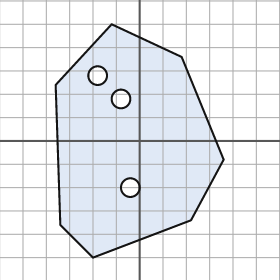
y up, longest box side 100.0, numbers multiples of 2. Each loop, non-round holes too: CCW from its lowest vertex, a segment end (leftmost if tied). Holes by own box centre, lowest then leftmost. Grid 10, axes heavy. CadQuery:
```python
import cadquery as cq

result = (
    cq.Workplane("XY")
    .moveTo(-20.0, -50.0)
    .lineTo(22.0, -34.0)
    .lineTo(36.0, -8.0)
    .lineTo(18.0, 36.0)
    .lineTo(-12.0, 50.0)
    .lineTo(-36.0, 24.0)
    .lineTo(-34.0, -36.0)
    .close()
    .moveTo(-4.0, -20.0)
    .circle(4.0)
    .moveTo(-8.0, 18.0)
    .circle(4.0)
    .moveTo(-18.0, 28.0)
    .circle(4.0)
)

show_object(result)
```